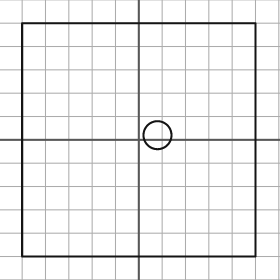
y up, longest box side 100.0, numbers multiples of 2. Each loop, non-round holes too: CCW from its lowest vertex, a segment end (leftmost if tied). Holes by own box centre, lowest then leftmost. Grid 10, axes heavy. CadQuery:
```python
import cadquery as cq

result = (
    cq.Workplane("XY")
    .moveTo(-50.0, -50.0)
    .lineTo(50.0, -50.0)
    .lineTo(50.0, 50.0)
    .lineTo(-50.0, 50.0)
    .close()
    .moveTo(8.0, 2.0)
    .circle(6.0)
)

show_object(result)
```